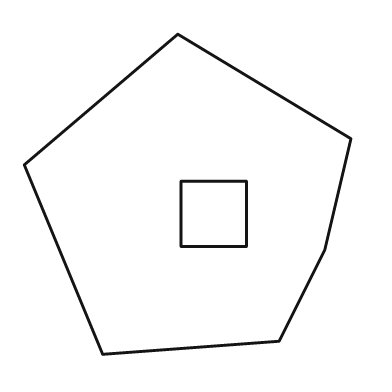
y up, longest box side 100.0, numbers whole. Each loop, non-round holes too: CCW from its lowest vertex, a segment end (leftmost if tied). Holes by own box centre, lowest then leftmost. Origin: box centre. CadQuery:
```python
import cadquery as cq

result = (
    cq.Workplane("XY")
    .moveTo(-26.0, -49.0)
    .lineTo(28.0, -45.0)
    .lineTo(42.0, -17.0)
    .lineTo(50.0, 17.0)
    .lineTo(-3.0, 49.0)
    .lineTo(-50.0, 9.0)
    .close()
    .moveTo(-2.0, -16.0)
    .lineTo(18.0, -16.0)
    .lineTo(18.0, 4.0)
    .lineTo(-2.0, 4.0)
    .close()
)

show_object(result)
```